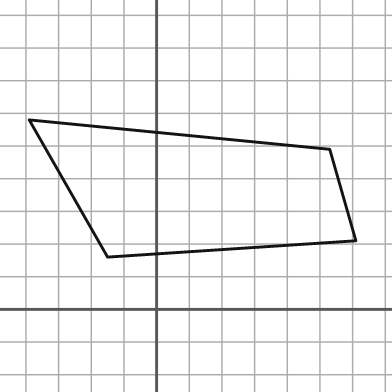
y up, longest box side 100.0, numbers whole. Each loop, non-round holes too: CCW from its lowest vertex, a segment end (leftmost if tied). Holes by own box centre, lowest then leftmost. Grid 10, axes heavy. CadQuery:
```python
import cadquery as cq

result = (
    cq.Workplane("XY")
    .moveTo(-15.0, 16.0)
    .lineTo(61.0, 21.0)
    .lineTo(53.0, 49.0)
    .lineTo(-39.0, 58.0)
    .close()
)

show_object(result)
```